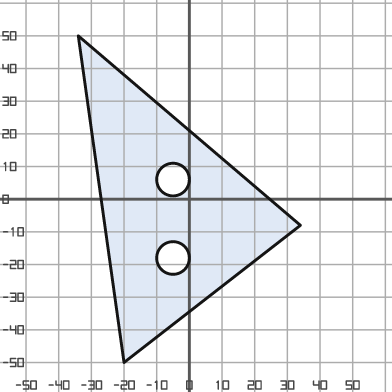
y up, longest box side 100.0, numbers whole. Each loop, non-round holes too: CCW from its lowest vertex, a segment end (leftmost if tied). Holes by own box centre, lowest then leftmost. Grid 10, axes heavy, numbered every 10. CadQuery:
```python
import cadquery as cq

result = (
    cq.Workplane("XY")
    .moveTo(-20.0, -50.0)
    .lineTo(34.0, -8.0)
    .lineTo(-34.0, 50.0)
    .close()
    .moveTo(-5.0, -18.0)
    .circle(5.0)
    .moveTo(-5.0, 6.0)
    .circle(5.0)
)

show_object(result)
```